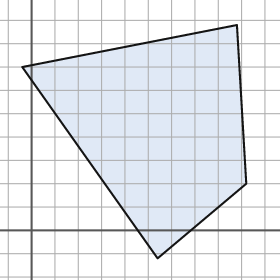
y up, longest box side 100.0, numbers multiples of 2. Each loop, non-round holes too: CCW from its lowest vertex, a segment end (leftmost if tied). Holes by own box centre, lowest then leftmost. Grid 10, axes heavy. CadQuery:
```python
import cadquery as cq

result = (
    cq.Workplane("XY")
    .moveTo(54.0, -12.0)
    .lineTo(92.0, 20.0)
    .lineTo(88.0, 88.0)
    .lineTo(-4.0, 70.0)
    .close()
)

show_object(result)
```